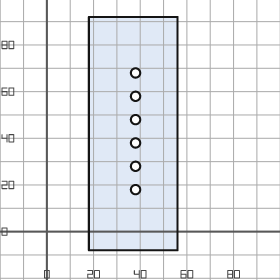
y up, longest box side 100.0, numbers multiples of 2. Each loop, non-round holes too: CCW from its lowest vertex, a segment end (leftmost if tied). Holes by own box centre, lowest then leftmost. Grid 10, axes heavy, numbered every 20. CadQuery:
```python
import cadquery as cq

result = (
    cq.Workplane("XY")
    .moveTo(18.0, -8.0)
    .lineTo(56.0, -8.0)
    .lineTo(56.0, 92.0)
    .lineTo(18.0, 92.0)
    .close()
    .moveTo(38.0, 18.0)
    .circle(2.0)
    .moveTo(38.0, 28.0)
    .circle(2.0)
    .moveTo(38.0, 38.0)
    .circle(2.0)
    .moveTo(38.0, 48.0)
    .circle(2.0)
    .moveTo(38.0, 58.0)
    .circle(2.0)
    .moveTo(38.0, 68.0)
    .circle(2.0)
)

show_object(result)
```